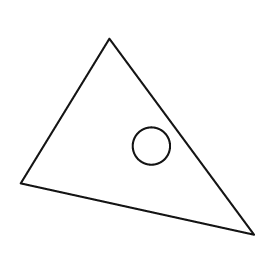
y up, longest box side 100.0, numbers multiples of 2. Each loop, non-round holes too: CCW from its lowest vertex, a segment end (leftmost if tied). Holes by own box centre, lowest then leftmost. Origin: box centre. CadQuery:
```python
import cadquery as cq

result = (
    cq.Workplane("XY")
    .moveTo(50.0, -42.0)
    .lineTo(-12.0, 42.0)
    .lineTo(-50.0, -20.0)
    .close()
    .moveTo(6.0, -4.0)
    .circle(8.0)
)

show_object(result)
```